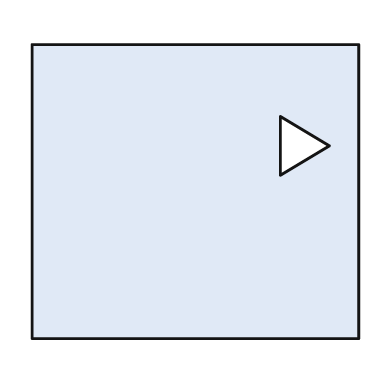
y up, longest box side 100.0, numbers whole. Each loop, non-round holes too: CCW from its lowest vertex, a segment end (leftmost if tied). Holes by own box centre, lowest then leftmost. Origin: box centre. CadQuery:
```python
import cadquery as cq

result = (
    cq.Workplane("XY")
    .moveTo(-50.0, -45.0)
    .lineTo(50.0, -45.0)
    .lineTo(50.0, 45.0)
    .lineTo(-50.0, 45.0)
    .close()
    .moveTo(26.0, 5.0)
    .lineTo(41.0, 14.0)
    .lineTo(26.0, 23.0)
    .close()
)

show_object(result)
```